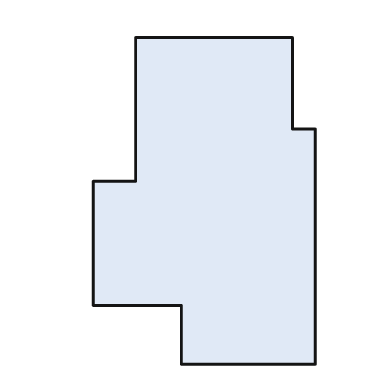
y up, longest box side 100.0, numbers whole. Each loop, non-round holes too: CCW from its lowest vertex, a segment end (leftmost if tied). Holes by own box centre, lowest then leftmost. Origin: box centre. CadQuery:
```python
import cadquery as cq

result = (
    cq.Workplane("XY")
    .moveTo(-7.0, -50.0)
    .lineTo(34.0, -50.0)
    .lineTo(34.0, 22.0)
    .lineTo(27.0, 22.0)
    .lineTo(27.0, 50.0)
    .lineTo(-21.0, 50.0)
    .lineTo(-21.0, 6.0)
    .lineTo(-34.0, 6.0)
    .lineTo(-34.0, -32.0)
    .lineTo(-7.0, -32.0)
    .close()
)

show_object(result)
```